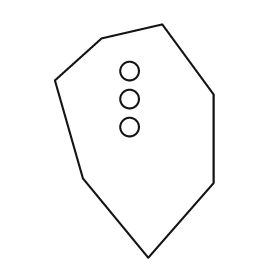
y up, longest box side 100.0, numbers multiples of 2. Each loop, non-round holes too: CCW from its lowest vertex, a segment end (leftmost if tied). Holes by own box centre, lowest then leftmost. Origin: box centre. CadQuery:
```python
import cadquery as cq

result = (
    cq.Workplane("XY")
    .moveTo(6.0, -50.0)
    .lineTo(34.0, -18.0)
    .lineTo(34.0, 20.0)
    .lineTo(12.0, 50.0)
    .lineTo(-14.0, 44.0)
    .lineTo(-34.0, 26.0)
    .lineTo(-22.0, -16.0)
    .close()
    .moveTo(-2.0, 6.0)
    .circle(4.0)
    .moveTo(-2.0, 18.0)
    .circle(4.0)
    .moveTo(-2.0, 30.0)
    .circle(4.0)
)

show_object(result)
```